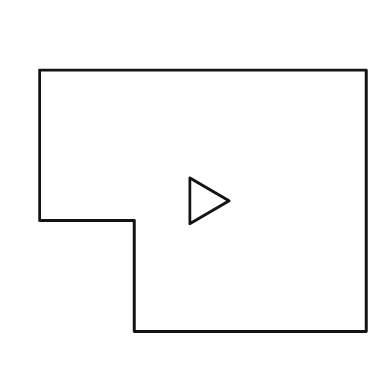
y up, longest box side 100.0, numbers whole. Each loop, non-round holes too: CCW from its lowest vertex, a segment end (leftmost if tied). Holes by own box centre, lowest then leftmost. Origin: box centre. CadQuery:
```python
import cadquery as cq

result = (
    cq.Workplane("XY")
    .moveTo(-21.0, -40.0)
    .lineTo(50.0, -40.0)
    .lineTo(50.0, 40.0)
    .lineTo(-50.0, 40.0)
    .lineTo(-50.0, -6.0)
    .lineTo(-21.0, -6.0)
    .close()
    .moveTo(-4.0, -7.0)
    .lineTo(8.0, 0.0)
    .lineTo(-4.0, 7.0)
    .close()
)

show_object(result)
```